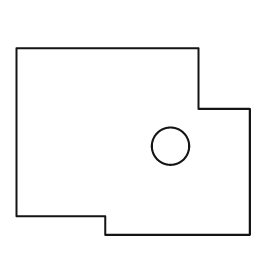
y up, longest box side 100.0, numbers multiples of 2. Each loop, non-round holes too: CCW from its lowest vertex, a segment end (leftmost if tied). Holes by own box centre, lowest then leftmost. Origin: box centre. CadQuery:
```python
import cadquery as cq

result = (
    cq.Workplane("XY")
    .moveTo(-12.0, -40.0)
    .lineTo(50.0, -40.0)
    .lineTo(50.0, 14.0)
    .lineTo(28.0, 14.0)
    .lineTo(28.0, 40.0)
    .lineTo(-50.0, 40.0)
    .lineTo(-50.0, -32.0)
    .lineTo(-12.0, -32.0)
    .close()
    .moveTo(16.0, -2.0)
    .circle(8.0)
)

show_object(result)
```